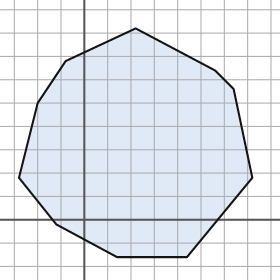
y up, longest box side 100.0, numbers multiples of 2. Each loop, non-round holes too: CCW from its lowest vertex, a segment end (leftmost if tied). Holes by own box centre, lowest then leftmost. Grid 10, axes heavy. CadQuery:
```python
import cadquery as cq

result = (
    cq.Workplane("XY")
    .moveTo(14.0, -16.0)
    .lineTo(44.0, -16.0)
    .lineTo(72.0, 18.0)
    .lineTo(64.0, 56.0)
    .lineTo(56.0, 64.0)
    .lineTo(22.0, 82.0)
    .lineTo(-8.0, 68.0)
    .lineTo(-20.0, 50.0)
    .lineTo(-28.0, 18.0)
    .lineTo(-12.0, -2.0)
    .close()
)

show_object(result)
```